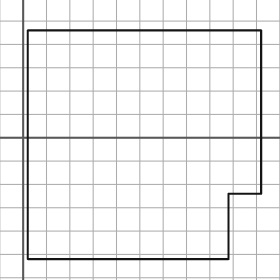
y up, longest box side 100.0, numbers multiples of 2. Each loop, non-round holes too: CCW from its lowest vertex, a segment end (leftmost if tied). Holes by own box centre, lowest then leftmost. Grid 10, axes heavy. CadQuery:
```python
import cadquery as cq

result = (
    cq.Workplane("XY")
    .moveTo(2.0, -52.0)
    .lineTo(88.0, -52.0)
    .lineTo(88.0, -24.0)
    .lineTo(102.0, -24.0)
    .lineTo(102.0, 46.0)
    .lineTo(2.0, 46.0)
    .close()
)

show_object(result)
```